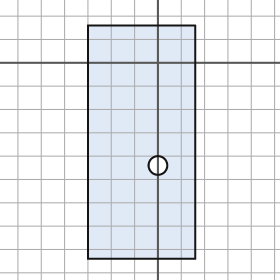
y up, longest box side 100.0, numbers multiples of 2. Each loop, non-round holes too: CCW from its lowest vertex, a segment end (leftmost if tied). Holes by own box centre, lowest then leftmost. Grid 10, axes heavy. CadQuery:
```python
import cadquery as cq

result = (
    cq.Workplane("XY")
    .moveTo(-30.0, -84.0)
    .lineTo(16.0, -84.0)
    .lineTo(16.0, 16.0)
    .lineTo(-30.0, 16.0)
    .close()
    .moveTo(0.0, -44.0)
    .circle(4.0)
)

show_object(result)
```